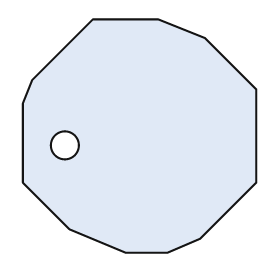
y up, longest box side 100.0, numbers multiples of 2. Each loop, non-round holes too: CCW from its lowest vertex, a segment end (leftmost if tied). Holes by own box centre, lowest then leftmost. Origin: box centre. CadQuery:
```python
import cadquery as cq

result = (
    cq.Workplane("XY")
    .moveTo(-6.0, -50.0)
    .lineTo(12.0, -50.0)
    .lineTo(26.0, -44.0)
    .lineTo(50.0, -20.0)
    .lineTo(50.0, 20.0)
    .lineTo(28.0, 42.0)
    .lineTo(8.0, 50.0)
    .lineTo(-20.0, 50.0)
    .lineTo(-46.0, 24.0)
    .lineTo(-50.0, 14.0)
    .lineTo(-50.0, -20.0)
    .lineTo(-30.0, -40.0)
    .close()
    .moveTo(-32.0, -4.0)
    .circle(6.0)
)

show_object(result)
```